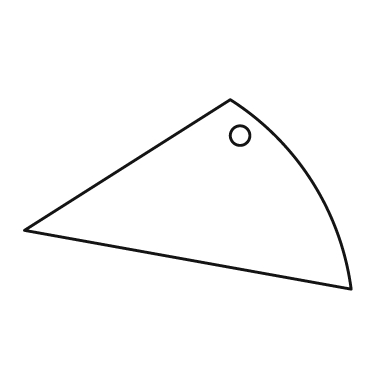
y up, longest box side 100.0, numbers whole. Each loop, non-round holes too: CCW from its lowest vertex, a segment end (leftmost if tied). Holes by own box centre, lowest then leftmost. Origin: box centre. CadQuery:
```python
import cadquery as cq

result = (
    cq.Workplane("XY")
    .moveTo(50.0, -29.0)
    .threePointArc((38.0, 4.0), (13.0, 29.0))
    .lineTo(-50.0, -11.0)
    .close()
    .moveTo(16.0, 18.0)
    .circle(3.0)
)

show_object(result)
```